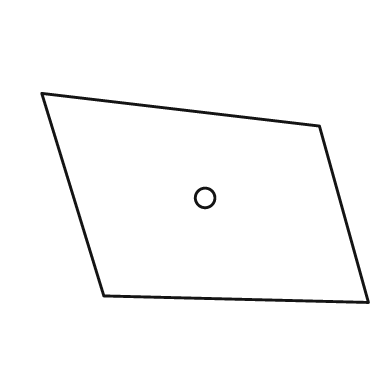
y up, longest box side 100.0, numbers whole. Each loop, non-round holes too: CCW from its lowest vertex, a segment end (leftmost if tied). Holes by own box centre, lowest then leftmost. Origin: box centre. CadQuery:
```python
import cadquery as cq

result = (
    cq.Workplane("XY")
    .moveTo(50.0, -32.0)
    .lineTo(35.0, 22.0)
    .lineTo(-50.0, 32.0)
    .lineTo(-31.0, -30.0)
    .close()
    .moveTo(0.0, 0.0)
    .circle(3.0)
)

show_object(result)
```